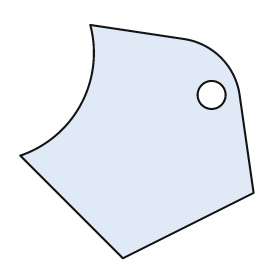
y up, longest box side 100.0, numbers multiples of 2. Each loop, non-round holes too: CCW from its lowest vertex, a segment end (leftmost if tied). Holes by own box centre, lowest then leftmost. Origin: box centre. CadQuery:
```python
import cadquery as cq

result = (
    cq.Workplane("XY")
    .moveTo(-6.0, -50.0)
    .lineTo(50.0, -22.0)
    .lineTo(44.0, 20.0)
    .threePointArc((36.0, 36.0), (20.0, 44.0))
    .lineTo(-20.0, 50.0)
    .threePointArc((-24.0, 16.0), (-50.0, -6.0))
    .close()
    .moveTo(32.0, 20.0)
    .circle(6.0)
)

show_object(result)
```